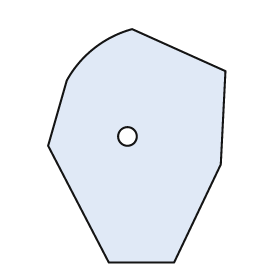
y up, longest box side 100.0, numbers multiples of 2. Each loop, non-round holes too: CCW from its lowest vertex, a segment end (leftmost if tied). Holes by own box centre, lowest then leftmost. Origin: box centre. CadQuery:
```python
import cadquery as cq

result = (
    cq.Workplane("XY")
    .moveTo(-12.0, -50.0)
    .lineTo(16.0, -50.0)
    .lineTo(36.0, -8.0)
    .lineTo(38.0, 32.0)
    .lineTo(-2.0, 50.0)
    .threePointArc((-18.0, 42.0), (-30.0, 28.0))
    .lineTo(-38.0, 0.0)
    .close()
    .moveTo(-4.0, 4.0)
    .circle(4.0)
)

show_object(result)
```